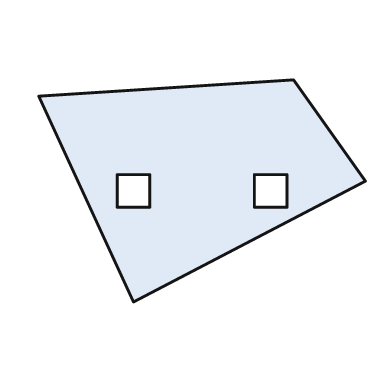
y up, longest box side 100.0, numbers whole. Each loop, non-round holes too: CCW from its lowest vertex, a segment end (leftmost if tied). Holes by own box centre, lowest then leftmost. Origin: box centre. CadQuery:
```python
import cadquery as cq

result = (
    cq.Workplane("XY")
    .moveTo(-21.0, -34.0)
    .lineTo(50.0, 3.0)
    .lineTo(28.0, 34.0)
    .lineTo(-50.0, 29.0)
    .close()
    .moveTo(-26.0, -5.0)
    .lineTo(-16.0, -5.0)
    .lineTo(-16.0, 5.0)
    .lineTo(-26.0, 5.0)
    .close()
    .moveTo(16.0, -5.0)
    .lineTo(26.0, -5.0)
    .lineTo(26.0, 5.0)
    .lineTo(16.0, 5.0)
    .close()
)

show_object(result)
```